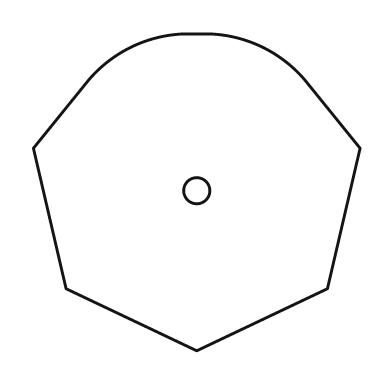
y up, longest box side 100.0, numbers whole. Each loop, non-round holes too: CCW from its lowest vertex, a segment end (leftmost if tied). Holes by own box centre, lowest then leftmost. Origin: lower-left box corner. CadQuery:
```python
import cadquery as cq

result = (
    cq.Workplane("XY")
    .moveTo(50.0, 0.0)
    .lineTo(90.0, 19.0)
    .lineTo(100.0, 62.0)
    .lineTo(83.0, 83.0)
    .threePointArc((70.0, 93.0), (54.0, 97.0))
    .lineTo(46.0, 97.0)
    .threePointArc((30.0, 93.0), (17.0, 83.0))
    .lineTo(0.0, 62.0)
    .lineTo(10.0, 19.0)
    .close()
    .moveTo(50.0, 49.0)
    .circle(4.0)
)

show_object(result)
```